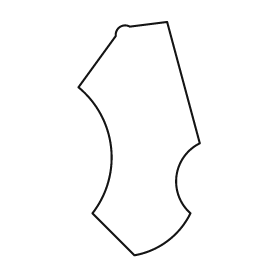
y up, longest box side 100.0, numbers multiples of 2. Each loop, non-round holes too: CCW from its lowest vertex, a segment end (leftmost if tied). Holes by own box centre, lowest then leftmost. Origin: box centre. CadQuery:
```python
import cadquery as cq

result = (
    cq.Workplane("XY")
    .moveTo(-2.0, -50.0)
    .threePointArc((12.0, -44.0), (22.0, -32.0))
    .threePointArc((16.0, -16.0), (26.0, -2.0))
    .lineTo(12.0, 50.0)
    .lineTo(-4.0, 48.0)
    .threePointArc((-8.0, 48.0), (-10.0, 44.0))
    .lineTo(-26.0, 22.0)
    .threePointArc((-12.0, -4.0), (-20.0, -32.0))
    .close()
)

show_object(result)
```